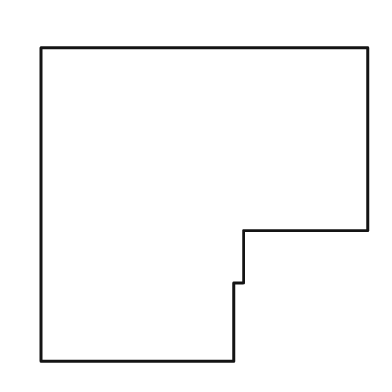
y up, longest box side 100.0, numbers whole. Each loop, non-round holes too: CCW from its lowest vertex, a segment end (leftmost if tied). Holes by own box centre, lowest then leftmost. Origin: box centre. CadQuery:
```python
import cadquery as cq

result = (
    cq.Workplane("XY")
    .moveTo(-50.0, -48.0)
    .lineTo(9.0, -48.0)
    .lineTo(9.0, -24.0)
    .lineTo(12.0, -24.0)
    .lineTo(12.0, -8.0)
    .lineTo(50.0, -8.0)
    .lineTo(50.0, 48.0)
    .lineTo(-50.0, 48.0)
    .close()
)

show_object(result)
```